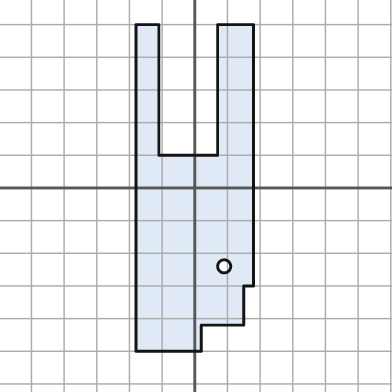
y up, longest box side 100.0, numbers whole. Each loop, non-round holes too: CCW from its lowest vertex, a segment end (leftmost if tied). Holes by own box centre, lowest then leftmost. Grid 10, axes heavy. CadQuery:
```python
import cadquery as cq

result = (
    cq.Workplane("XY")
    .moveTo(-18.0, -50.0)
    .lineTo(2.0, -50.0)
    .lineTo(2.0, -42.0)
    .lineTo(15.0, -42.0)
    .lineTo(15.0, -30.0)
    .lineTo(18.0, -30.0)
    .lineTo(18.0, 50.0)
    .lineTo(7.0, 50.0)
    .lineTo(7.0, 10.0)
    .lineTo(-11.0, 10.0)
    .lineTo(-11.0, 50.0)
    .lineTo(-18.0, 50.0)
    .close()
    .moveTo(9.0, -24.0)
    .circle(2.0)
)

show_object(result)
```